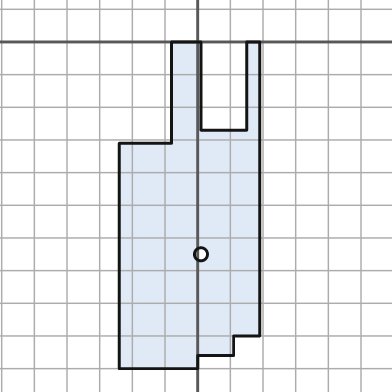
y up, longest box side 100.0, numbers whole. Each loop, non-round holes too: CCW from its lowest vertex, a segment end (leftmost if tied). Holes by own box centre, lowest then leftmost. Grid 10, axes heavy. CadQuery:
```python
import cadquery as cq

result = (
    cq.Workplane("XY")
    .moveTo(-24.0, -100.0)
    .lineTo(0.0, -100.0)
    .lineTo(0.0, -96.0)
    .lineTo(11.0, -96.0)
    .lineTo(11.0, -90.0)
    .lineTo(19.0, -90.0)
    .lineTo(19.0, 0.0)
    .lineTo(15.0, 0.0)
    .lineTo(15.0, -27.0)
    .lineTo(1.0, -27.0)
    .lineTo(1.0, 0.0)
    .lineTo(-8.0, 0.0)
    .lineTo(-8.0, -31.0)
    .lineTo(-24.0, -31.0)
    .close()
    .moveTo(1.0, -65.0)
    .circle(2.0)
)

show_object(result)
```